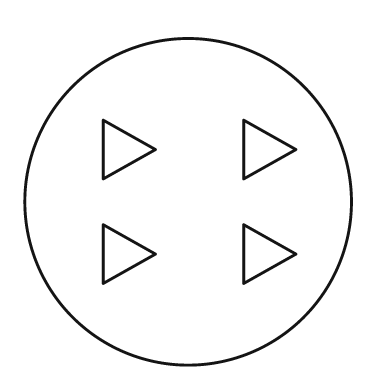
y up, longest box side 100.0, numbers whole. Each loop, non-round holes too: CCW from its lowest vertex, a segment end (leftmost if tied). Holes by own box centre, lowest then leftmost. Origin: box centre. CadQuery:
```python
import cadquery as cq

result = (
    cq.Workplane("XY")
    .moveTo(0.0, 0.0)
    .circle(50.0)
    .moveTo(-26.0, -25.0)
    .lineTo(-10.0, -16.0)
    .lineTo(-26.0, -7.0)
    .close()
    .moveTo(17.0, -25.0)
    .lineTo(33.0, -16.0)
    .lineTo(17.0, -7.0)
    .close()
    .moveTo(-26.0, 7.0)
    .lineTo(-10.0, 16.0)
    .lineTo(-26.0, 25.0)
    .close()
    .moveTo(17.0, 7.0)
    .lineTo(33.0, 16.0)
    .lineTo(17.0, 25.0)
    .close()
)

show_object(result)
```